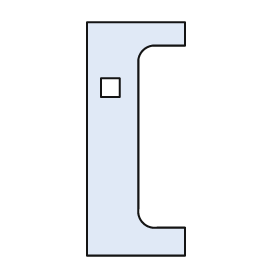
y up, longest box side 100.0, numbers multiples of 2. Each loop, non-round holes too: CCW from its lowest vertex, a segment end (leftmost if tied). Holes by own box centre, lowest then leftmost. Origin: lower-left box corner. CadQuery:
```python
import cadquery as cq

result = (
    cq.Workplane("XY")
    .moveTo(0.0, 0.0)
    .lineTo(42.0, 0.0)
    .lineTo(42.0, 12.0)
    .lineTo(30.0, 12.0)
    .threePointArc((24.0, 14.0), (22.0, 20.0))
    .lineTo(22.0, 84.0)
    .threePointArc((24.0, 88.0), (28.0, 90.0))
    .lineTo(42.0, 90.0)
    .lineTo(42.0, 100.0)
    .lineTo(0.0, 100.0)
    .close()
    .moveTo(6.0, 68.0)
    .lineTo(14.0, 68.0)
    .lineTo(14.0, 76.0)
    .lineTo(6.0, 76.0)
    .close()
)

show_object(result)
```